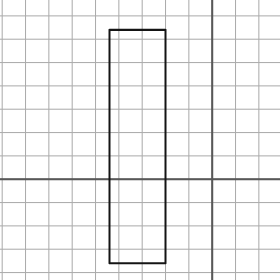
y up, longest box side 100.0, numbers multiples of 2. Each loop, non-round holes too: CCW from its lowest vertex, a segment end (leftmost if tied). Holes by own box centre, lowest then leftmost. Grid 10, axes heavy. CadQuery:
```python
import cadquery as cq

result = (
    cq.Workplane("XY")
    .moveTo(-44.0, -36.0)
    .lineTo(-20.0, -36.0)
    .lineTo(-20.0, 64.0)
    .lineTo(-44.0, 64.0)
    .close()
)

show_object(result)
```